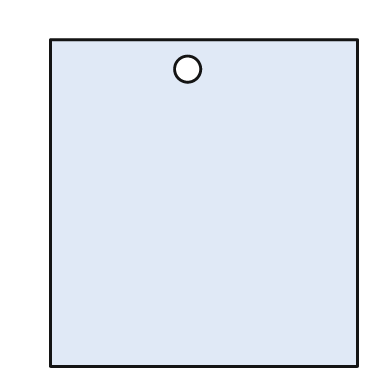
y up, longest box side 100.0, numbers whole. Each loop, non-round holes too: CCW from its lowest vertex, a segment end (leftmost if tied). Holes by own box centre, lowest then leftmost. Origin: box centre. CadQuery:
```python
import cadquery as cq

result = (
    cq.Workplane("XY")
    .moveTo(-47.0, -50.0)
    .lineTo(47.0, -50.0)
    .lineTo(47.0, 50.0)
    .lineTo(-47.0, 50.0)
    .close()
    .moveTo(-5.0, 41.0)
    .circle(4.0)
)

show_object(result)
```